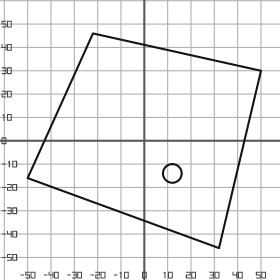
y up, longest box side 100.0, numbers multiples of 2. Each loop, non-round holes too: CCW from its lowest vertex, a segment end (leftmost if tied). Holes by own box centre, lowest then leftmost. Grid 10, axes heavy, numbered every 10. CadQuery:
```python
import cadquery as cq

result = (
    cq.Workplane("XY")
    .moveTo(32.0, -46.0)
    .lineTo(50.0, 30.0)
    .lineTo(-22.0, 46.0)
    .lineTo(-50.0, -16.0)
    .close()
    .moveTo(12.0, -14.0)
    .circle(4.0)
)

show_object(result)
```